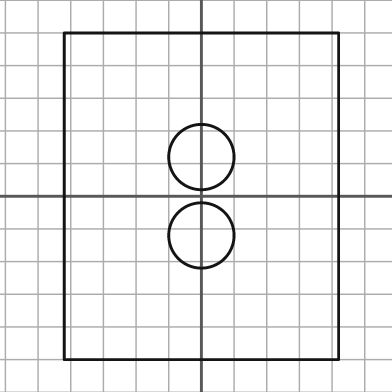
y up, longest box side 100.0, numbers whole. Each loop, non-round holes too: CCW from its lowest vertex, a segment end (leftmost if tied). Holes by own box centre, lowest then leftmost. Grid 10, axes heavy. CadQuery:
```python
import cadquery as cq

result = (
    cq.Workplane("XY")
    .moveTo(-42.0, -50.0)
    .lineTo(42.0, -50.0)
    .lineTo(42.0, 50.0)
    .lineTo(-42.0, 50.0)
    .close()
    .moveTo(0.0, -12.0)
    .circle(10.0)
    .moveTo(0.0, 12.0)
    .circle(10.0)
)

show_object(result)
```